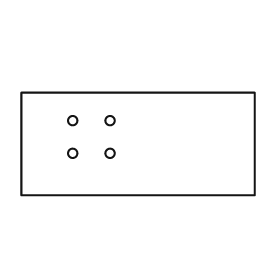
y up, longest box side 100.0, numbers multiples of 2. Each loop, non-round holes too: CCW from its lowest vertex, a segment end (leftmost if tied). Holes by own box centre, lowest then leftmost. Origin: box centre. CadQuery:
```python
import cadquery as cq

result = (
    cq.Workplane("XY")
    .moveTo(-50.0, -22.0)
    .lineTo(50.0, -22.0)
    .lineTo(50.0, 22.0)
    .lineTo(-50.0, 22.0)
    .close()
    .moveTo(-28.0, -4.0)
    .circle(2.0)
    .moveTo(-12.0, -4.0)
    .circle(2.0)
    .moveTo(-28.0, 10.0)
    .circle(2.0)
    .moveTo(-12.0, 10.0)
    .circle(2.0)
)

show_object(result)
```